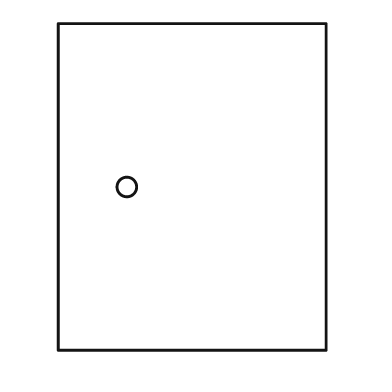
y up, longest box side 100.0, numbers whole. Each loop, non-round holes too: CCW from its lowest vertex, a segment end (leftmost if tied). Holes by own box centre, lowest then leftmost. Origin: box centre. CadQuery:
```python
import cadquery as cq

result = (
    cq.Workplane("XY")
    .moveTo(-41.0, -50.0)
    .lineTo(41.0, -50.0)
    .lineTo(41.0, 50.0)
    .lineTo(-41.0, 50.0)
    .close()
    .moveTo(-20.0, 0.0)
    .circle(3.0)
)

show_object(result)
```